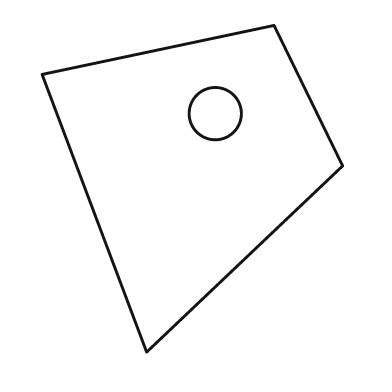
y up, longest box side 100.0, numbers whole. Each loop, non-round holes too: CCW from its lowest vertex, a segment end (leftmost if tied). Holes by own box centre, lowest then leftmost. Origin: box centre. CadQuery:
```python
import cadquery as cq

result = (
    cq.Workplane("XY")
    .moveTo(-14.0, -50.0)
    .lineTo(46.0, 7.0)
    .lineTo(25.0, 50.0)
    .lineTo(-46.0, 35.0)
    .close()
    .moveTo(7.0, 23.0)
    .circle(8.0)
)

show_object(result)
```